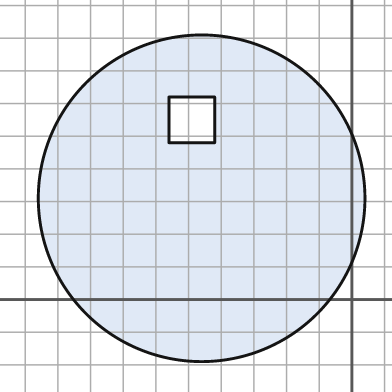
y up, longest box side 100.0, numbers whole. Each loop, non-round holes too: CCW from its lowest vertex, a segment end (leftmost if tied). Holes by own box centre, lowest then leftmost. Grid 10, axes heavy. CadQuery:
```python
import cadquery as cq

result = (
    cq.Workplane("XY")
    .moveTo(-46.0, 31.0)
    .circle(50.0)
    .moveTo(-56.0, 48.0)
    .lineTo(-42.0, 48.0)
    .lineTo(-42.0, 62.0)
    .lineTo(-56.0, 62.0)
    .close()
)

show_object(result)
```